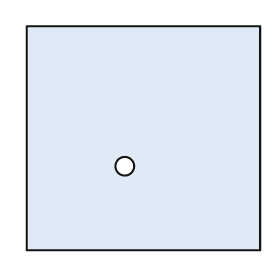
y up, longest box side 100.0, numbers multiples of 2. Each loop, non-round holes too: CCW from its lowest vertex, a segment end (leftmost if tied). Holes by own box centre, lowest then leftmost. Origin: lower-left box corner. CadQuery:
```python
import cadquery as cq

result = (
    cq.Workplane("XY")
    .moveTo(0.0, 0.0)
    .lineTo(100.0, 0.0)
    .lineTo(100.0, 96.0)
    .lineTo(0.0, 96.0)
    .close()
    .moveTo(42.0, 36.0)
    .circle(4.0)
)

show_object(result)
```